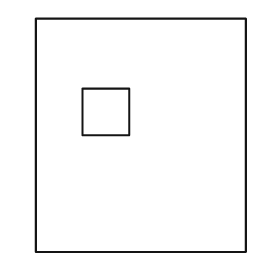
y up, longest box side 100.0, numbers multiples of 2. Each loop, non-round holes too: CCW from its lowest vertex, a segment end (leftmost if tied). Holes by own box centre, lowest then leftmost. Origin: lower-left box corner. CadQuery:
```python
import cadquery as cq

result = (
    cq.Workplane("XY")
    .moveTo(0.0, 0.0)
    .lineTo(90.0, 0.0)
    .lineTo(90.0, 100.0)
    .lineTo(0.0, 100.0)
    .close()
    .moveTo(20.0, 50.0)
    .lineTo(40.0, 50.0)
    .lineTo(40.0, 70.0)
    .lineTo(20.0, 70.0)
    .close()
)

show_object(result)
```